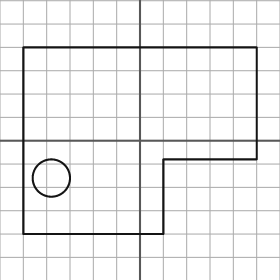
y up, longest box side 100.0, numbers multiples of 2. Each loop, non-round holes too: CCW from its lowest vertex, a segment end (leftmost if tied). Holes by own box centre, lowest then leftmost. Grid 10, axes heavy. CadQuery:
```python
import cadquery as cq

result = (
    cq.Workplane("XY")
    .moveTo(-50.0, -40.0)
    .lineTo(10.0, -40.0)
    .lineTo(10.0, -8.0)
    .lineTo(50.0, -8.0)
    .lineTo(50.0, 40.0)
    .lineTo(-50.0, 40.0)
    .close()
    .moveTo(-38.0, -16.0)
    .circle(8.0)
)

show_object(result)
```